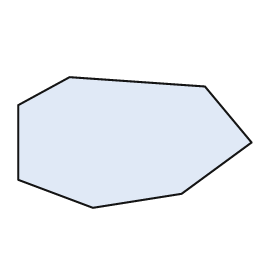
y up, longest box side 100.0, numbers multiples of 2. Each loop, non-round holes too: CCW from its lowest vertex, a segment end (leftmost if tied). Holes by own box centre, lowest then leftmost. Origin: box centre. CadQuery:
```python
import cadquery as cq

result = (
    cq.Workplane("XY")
    .moveTo(-18.0, -28.0)
    .lineTo(20.0, -22.0)
    .lineTo(50.0, 0.0)
    .lineTo(30.0, 24.0)
    .lineTo(-28.0, 28.0)
    .lineTo(-50.0, 16.0)
    .lineTo(-50.0, -16.0)
    .close()
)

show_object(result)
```